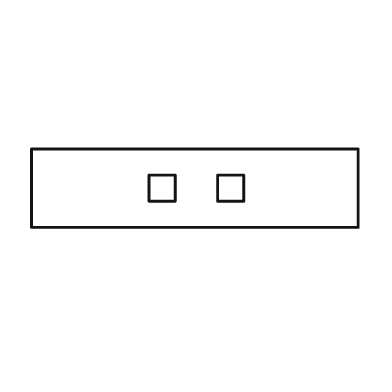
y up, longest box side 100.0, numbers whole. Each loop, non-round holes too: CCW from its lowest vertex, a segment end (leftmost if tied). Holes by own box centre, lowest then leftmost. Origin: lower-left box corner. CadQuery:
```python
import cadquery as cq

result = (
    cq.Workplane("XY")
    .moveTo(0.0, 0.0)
    .lineTo(100.0, 0.0)
    .lineTo(100.0, 24.0)
    .lineTo(0.0, 24.0)
    .close()
    .moveTo(36.0, 8.0)
    .lineTo(44.0, 8.0)
    .lineTo(44.0, 16.0)
    .lineTo(36.0, 16.0)
    .close()
    .moveTo(57.0, 8.0)
    .lineTo(65.0, 8.0)
    .lineTo(65.0, 16.0)
    .lineTo(57.0, 16.0)
    .close()
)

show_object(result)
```